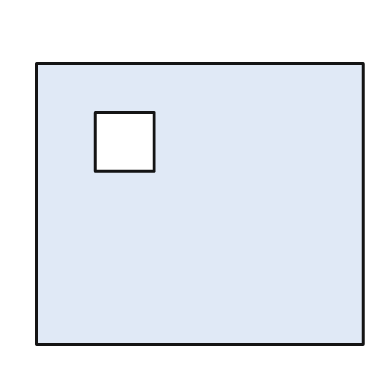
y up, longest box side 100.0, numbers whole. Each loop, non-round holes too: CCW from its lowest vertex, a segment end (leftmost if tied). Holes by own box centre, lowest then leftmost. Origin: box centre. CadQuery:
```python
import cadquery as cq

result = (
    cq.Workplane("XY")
    .moveTo(-50.0, -43.0)
    .lineTo(50.0, -43.0)
    .lineTo(50.0, 43.0)
    .lineTo(-50.0, 43.0)
    .close()
    .moveTo(-32.0, 10.0)
    .lineTo(-14.0, 10.0)
    .lineTo(-14.0, 28.0)
    .lineTo(-32.0, 28.0)
    .close()
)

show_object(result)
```